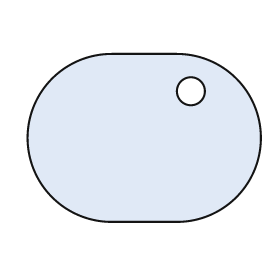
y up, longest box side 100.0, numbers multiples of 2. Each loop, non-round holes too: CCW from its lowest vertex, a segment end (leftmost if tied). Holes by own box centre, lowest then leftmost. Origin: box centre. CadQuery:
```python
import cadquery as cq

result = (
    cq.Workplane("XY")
    .moveTo(-14.0, -36.0)
    .lineTo(14.0, -36.0)
    .threePointArc((50.0, 0.0), (14.0, 36.0))
    .lineTo(-14.0, 36.0)
    .threePointArc((-50.0, 0.0), (-14.0, -36.0))
    .close()
    .moveTo(20.0, 20.0)
    .circle(6.0)
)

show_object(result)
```